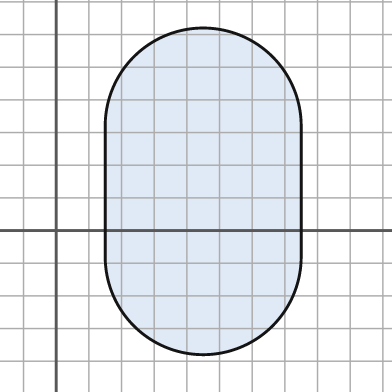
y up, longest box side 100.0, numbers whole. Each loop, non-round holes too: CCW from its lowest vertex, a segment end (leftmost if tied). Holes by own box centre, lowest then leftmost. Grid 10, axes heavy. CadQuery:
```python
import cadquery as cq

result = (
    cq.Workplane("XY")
    .moveTo(15.0, -8.0)
    .threePointArc((45.0, -38.0), (75.0, -8.0))
    .lineTo(75.0, 32.0)
    .threePointArc((45.0, 62.0), (15.0, 32.0))
    .close()
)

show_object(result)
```